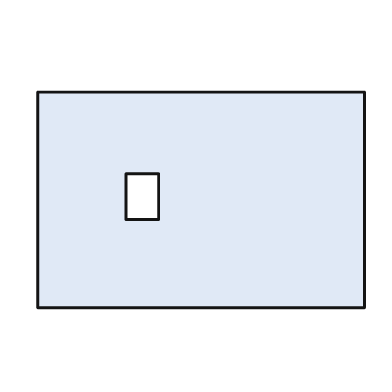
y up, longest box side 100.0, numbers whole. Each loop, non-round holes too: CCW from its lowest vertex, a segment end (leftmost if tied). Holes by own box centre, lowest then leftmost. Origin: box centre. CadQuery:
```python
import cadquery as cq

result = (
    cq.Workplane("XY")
    .moveTo(-50.0, -33.0)
    .lineTo(50.0, -33.0)
    .lineTo(50.0, 33.0)
    .lineTo(-50.0, 33.0)
    .close()
    .moveTo(-23.0, -6.0)
    .lineTo(-13.0, -6.0)
    .lineTo(-13.0, 8.0)
    .lineTo(-23.0, 8.0)
    .close()
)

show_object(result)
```